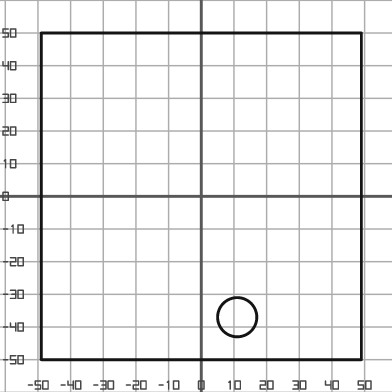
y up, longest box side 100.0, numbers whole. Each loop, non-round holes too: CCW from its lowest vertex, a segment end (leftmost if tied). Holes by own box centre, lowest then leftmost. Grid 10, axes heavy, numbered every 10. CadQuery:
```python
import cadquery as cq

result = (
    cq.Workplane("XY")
    .moveTo(-49.0, -50.0)
    .lineTo(49.0, -50.0)
    .lineTo(49.0, 50.0)
    .lineTo(-49.0, 50.0)
    .close()
    .moveTo(11.0, -37.0)
    .circle(6.0)
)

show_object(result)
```